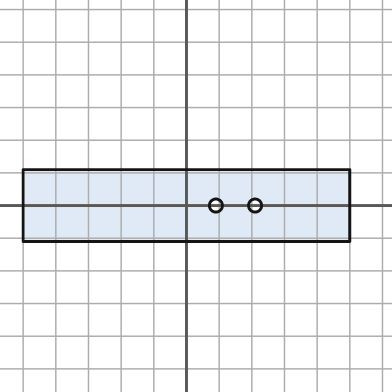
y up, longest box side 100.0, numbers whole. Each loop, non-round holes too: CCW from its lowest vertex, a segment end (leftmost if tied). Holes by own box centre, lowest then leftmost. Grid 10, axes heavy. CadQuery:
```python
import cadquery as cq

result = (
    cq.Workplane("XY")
    .moveTo(-50.0, -11.0)
    .lineTo(50.0, -11.0)
    .lineTo(50.0, 11.0)
    .lineTo(-50.0, 11.0)
    .close()
    .moveTo(9.0, 0.0)
    .circle(2.0)
    .moveTo(21.0, 0.0)
    .circle(2.0)
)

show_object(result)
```